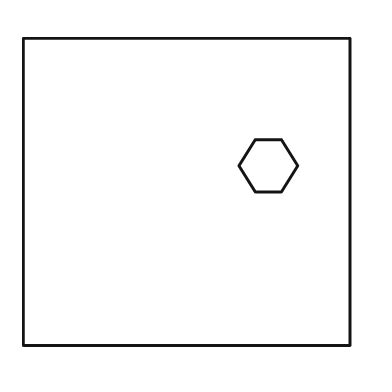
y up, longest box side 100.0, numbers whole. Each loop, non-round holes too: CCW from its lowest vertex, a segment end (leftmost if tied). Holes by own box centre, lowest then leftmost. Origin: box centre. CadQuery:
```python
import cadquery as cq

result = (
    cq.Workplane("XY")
    .moveTo(-50.0, -47.0)
    .lineTo(50.0, -47.0)
    .lineTo(50.0, 47.0)
    .lineTo(-50.0, 47.0)
    .close()
    .moveTo(21.0, 0.0)
    .lineTo(29.0, 0.0)
    .lineTo(34.0, 8.0)
    .lineTo(29.0, 16.0)
    .lineTo(21.0, 16.0)
    .lineTo(16.0, 8.0)
    .close()
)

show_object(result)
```